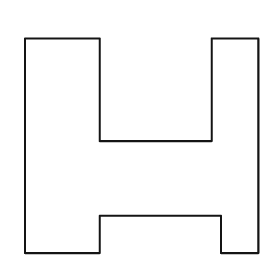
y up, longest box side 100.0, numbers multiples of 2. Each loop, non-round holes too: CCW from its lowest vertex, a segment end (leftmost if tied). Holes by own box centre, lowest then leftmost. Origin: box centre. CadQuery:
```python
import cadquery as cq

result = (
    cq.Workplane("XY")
    .moveTo(-50.0, -46.0)
    .lineTo(-18.0, -46.0)
    .lineTo(-18.0, -30.0)
    .lineTo(34.0, -30.0)
    .lineTo(34.0, -46.0)
    .lineTo(50.0, -46.0)
    .lineTo(50.0, 46.0)
    .lineTo(30.0, 46.0)
    .lineTo(30.0, 2.0)
    .lineTo(-18.0, 2.0)
    .lineTo(-18.0, 46.0)
    .lineTo(-50.0, 46.0)
    .close()
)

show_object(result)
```